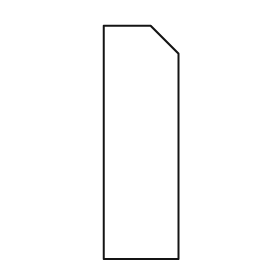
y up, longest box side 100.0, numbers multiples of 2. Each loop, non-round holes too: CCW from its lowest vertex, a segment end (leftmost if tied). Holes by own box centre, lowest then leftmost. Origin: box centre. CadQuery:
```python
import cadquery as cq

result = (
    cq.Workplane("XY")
    .moveTo(-16.0, -50.0)
    .lineTo(16.0, -50.0)
    .lineTo(16.0, 38.0)
    .lineTo(4.0, 50.0)
    .lineTo(-16.0, 50.0)
    .close()
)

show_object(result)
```